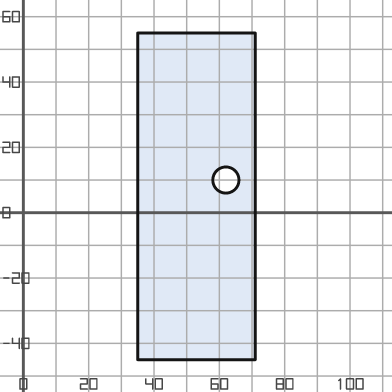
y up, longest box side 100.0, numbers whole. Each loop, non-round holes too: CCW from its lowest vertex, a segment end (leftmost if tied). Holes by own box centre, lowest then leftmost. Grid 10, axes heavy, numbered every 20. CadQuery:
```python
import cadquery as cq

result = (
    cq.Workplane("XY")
    .moveTo(35.0, -45.0)
    .lineTo(71.0, -45.0)
    .lineTo(71.0, 55.0)
    .lineTo(35.0, 55.0)
    .close()
    .moveTo(62.0, 10.0)
    .circle(4.0)
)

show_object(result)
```